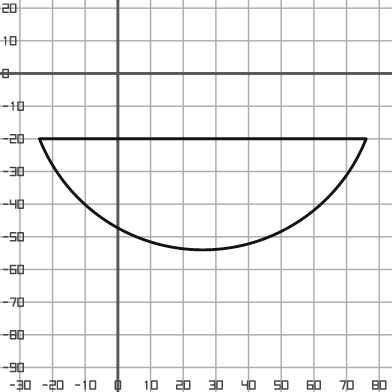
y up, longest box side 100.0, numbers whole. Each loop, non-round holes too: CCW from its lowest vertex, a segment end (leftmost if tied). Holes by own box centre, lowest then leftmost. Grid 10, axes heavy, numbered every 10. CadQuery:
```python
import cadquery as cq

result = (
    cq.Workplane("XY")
    .moveTo(-24.0, -20.0)
    .threePointArc((26.0, -54.0), (76.0, -20.0))
    .close()
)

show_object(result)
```